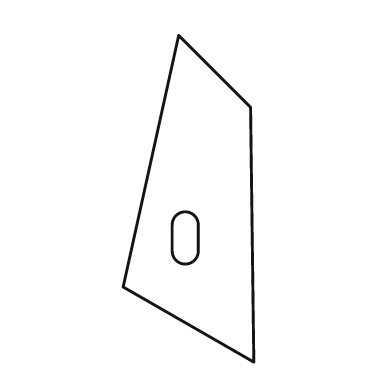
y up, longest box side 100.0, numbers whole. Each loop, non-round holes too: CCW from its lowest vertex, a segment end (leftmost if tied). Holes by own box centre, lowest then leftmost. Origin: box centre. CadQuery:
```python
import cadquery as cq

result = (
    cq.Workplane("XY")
    .moveTo(20.0, -50.0)
    .lineTo(19.0, 28.0)
    .lineTo(-3.0, 50.0)
    .lineTo(-20.0, -27.0)
    .close()
    .moveTo(-5.0, -16.0)
    .threePointArc((-1.0, -20.0), (3.0, -16.0))
    .lineTo(3.0, -8.0)
    .threePointArc((-1.0, -4.0), (-5.0, -8.0))
    .close()
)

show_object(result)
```